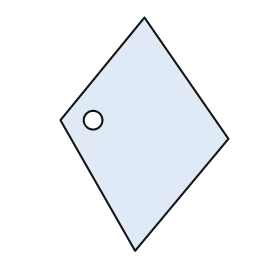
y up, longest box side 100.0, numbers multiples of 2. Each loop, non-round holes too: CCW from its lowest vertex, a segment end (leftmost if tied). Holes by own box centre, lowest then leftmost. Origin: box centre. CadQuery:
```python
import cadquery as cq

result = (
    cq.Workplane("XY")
    .moveTo(-4.0, -50.0)
    .lineTo(36.0, -2.0)
    .lineTo(0.0, 50.0)
    .lineTo(-36.0, 6.0)
    .close()
    .moveTo(-22.0, 6.0)
    .circle(4.0)
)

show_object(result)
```